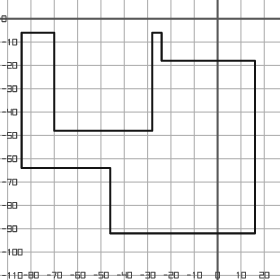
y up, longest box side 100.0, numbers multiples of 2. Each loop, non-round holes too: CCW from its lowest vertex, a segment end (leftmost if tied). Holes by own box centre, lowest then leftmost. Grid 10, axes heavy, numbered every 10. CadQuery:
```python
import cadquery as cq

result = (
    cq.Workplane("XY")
    .moveTo(-46.0, -92.0)
    .lineTo(16.0, -92.0)
    .lineTo(16.0, -18.0)
    .lineTo(-24.0, -18.0)
    .lineTo(-24.0, -6.0)
    .lineTo(-28.0, -6.0)
    .lineTo(-28.0, -48.0)
    .lineTo(-70.0, -48.0)
    .lineTo(-70.0, -6.0)
    .lineTo(-84.0, -6.0)
    .lineTo(-84.0, -64.0)
    .lineTo(-46.0, -64.0)
    .close()
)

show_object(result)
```